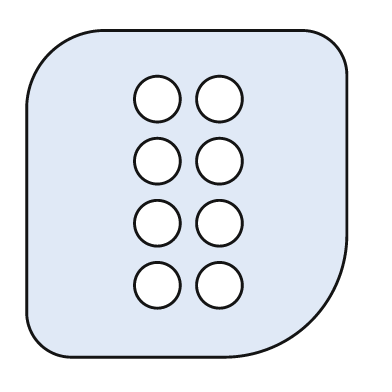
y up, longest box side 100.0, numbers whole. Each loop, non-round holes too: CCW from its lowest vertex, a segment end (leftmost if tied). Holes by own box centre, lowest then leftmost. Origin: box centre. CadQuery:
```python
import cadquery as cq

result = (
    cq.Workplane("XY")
    .moveTo(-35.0, -50.0)
    .lineTo(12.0, -50.0)
    .threePointArc((38.0, -39.0), (49.0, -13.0))
    .lineTo(49.0, 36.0)
    .threePointArc((45.0, 46.0), (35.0, 50.0))
    .lineTo(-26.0, 50.0)
    .threePointArc((-42.0, 43.0), (-49.0, 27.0))
    .lineTo(-49.0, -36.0)
    .threePointArc((-45.0, -46.0), (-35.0, -50.0))
    .close()
    .moveTo(-9.0, -28.0)
    .circle(7.0)
    .moveTo(10.0, -28.0)
    .circle(7.0)
    .moveTo(-9.0, -9.0)
    .circle(7.0)
    .moveTo(10.0, -9.0)
    .circle(7.0)
    .moveTo(-9.0, 10.0)
    .circle(7.0)
    .moveTo(10.0, 10.0)
    .circle(7.0)
    .moveTo(-9.0, 29.0)
    .circle(7.0)
    .moveTo(10.0, 29.0)
    .circle(7.0)
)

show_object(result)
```